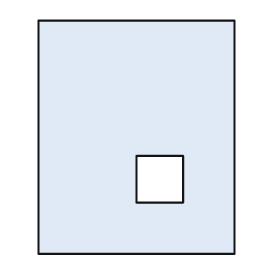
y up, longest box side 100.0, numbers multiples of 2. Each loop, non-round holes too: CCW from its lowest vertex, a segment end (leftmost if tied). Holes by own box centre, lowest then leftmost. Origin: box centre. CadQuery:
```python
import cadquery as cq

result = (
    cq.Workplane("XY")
    .moveTo(-42.0, -50.0)
    .lineTo(42.0, -50.0)
    .lineTo(42.0, 50.0)
    .lineTo(-42.0, 50.0)
    .close()
    .moveTo(0.0, -28.0)
    .lineTo(20.0, -28.0)
    .lineTo(20.0, -8.0)
    .lineTo(0.0, -8.0)
    .close()
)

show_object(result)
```